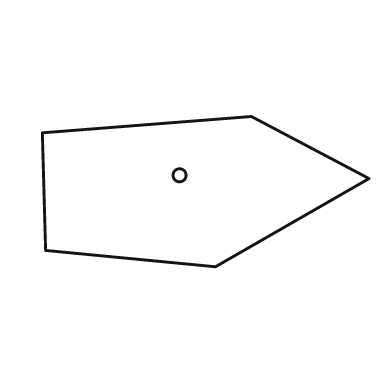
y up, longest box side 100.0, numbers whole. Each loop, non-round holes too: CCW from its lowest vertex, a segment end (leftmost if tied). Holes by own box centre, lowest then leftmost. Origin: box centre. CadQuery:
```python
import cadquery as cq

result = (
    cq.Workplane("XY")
    .moveTo(3.0, -23.0)
    .lineTo(50.0, 4.0)
    .lineTo(14.0, 23.0)
    .lineTo(-50.0, 18.0)
    .lineTo(-49.0, -18.0)
    .close()
    .moveTo(-8.0, 5.0)
    .circle(2.0)
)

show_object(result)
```